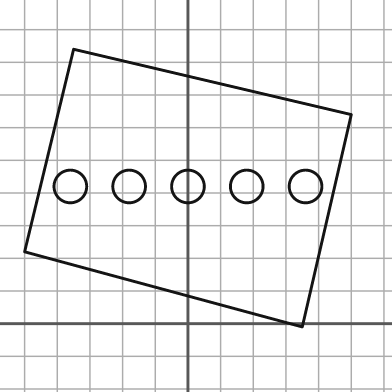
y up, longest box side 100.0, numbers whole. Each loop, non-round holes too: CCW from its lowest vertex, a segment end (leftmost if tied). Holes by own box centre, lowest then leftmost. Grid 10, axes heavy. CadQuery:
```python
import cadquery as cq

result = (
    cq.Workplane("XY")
    .moveTo(35.0, -1.0)
    .lineTo(50.0, 64.0)
    .lineTo(-35.0, 84.0)
    .lineTo(-50.0, 22.0)
    .close()
    .moveTo(-36.0, 42.0)
    .circle(5.0)
    .moveTo(-18.0, 42.0)
    .circle(5.0)
    .moveTo(0.0, 42.0)
    .circle(5.0)
    .moveTo(18.0, 42.0)
    .circle(5.0)
    .moveTo(36.0, 42.0)
    .circle(5.0)
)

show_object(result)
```